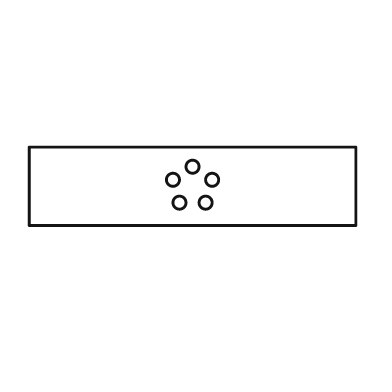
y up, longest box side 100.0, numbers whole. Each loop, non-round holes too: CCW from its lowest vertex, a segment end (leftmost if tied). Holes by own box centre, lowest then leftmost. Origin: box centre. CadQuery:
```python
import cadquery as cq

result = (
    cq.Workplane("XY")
    .moveTo(-50.0, -12.0)
    .lineTo(50.0, -12.0)
    .lineTo(50.0, 12.0)
    .lineTo(-50.0, 12.0)
    .close()
    .moveTo(-4.0, -5.0)
    .circle(2.0)
    .moveTo(4.0, -5.0)
    .circle(2.0)
    .moveTo(-6.0, 2.0)
    .circle(2.0)
    .moveTo(6.0, 2.0)
    .circle(2.0)
    .moveTo(0.0, 6.0)
    .circle(2.0)
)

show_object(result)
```